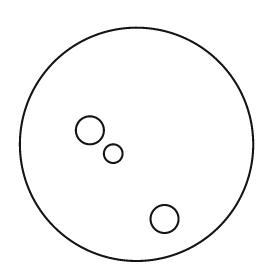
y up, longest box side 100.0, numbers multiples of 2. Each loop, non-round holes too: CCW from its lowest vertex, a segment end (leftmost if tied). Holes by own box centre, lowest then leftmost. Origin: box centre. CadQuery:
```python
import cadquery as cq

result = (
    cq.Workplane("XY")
    .moveTo(0.0, 0.0)
    .circle(50.0)
    .moveTo(12.0, -32.0)
    .circle(6.0)
    .moveTo(-10.0, -4.0)
    .circle(4.0)
    .moveTo(-20.0, 6.0)
    .circle(6.0)
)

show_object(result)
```